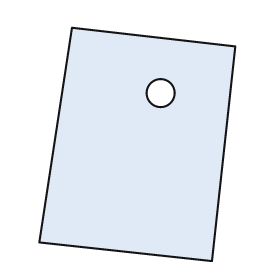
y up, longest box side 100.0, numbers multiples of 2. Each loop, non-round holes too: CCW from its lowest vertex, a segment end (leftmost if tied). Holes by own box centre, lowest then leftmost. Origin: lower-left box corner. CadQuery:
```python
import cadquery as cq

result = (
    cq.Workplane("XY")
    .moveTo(74.0, 0.0)
    .lineTo(84.0, 92.0)
    .lineTo(14.0, 100.0)
    .lineTo(0.0, 8.0)
    .close()
    .moveTo(52.0, 72.0)
    .circle(6.0)
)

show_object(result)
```